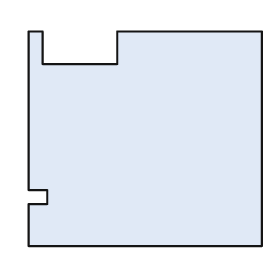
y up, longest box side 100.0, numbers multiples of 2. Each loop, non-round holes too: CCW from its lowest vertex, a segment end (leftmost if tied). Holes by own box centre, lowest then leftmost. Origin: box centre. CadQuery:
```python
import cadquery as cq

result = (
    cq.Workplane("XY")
    .moveTo(-50.0, -46.0)
    .lineTo(50.0, -46.0)
    .lineTo(50.0, 46.0)
    .lineTo(-12.0, 46.0)
    .lineTo(-12.0, 32.0)
    .lineTo(-44.0, 32.0)
    .lineTo(-44.0, 46.0)
    .lineTo(-50.0, 46.0)
    .lineTo(-50.0, -22.0)
    .lineTo(-42.0, -22.0)
    .lineTo(-42.0, -28.0)
    .lineTo(-50.0, -28.0)
    .close()
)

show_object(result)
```